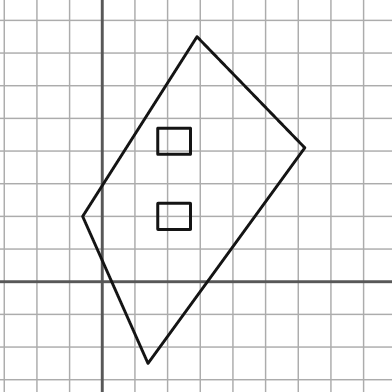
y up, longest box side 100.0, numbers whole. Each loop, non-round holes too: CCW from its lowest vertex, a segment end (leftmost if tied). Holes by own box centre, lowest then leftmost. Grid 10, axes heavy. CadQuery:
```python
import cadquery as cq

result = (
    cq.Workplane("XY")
    .moveTo(14.0, -25.0)
    .lineTo(62.0, 41.0)
    .lineTo(29.0, 75.0)
    .lineTo(-6.0, 20.0)
    .close()
    .moveTo(17.0, 16.0)
    .lineTo(27.0, 16.0)
    .lineTo(27.0, 24.0)
    .lineTo(17.0, 24.0)
    .close()
    .moveTo(17.0, 39.0)
    .lineTo(27.0, 39.0)
    .lineTo(27.0, 47.0)
    .lineTo(17.0, 47.0)
    .close()
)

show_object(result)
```